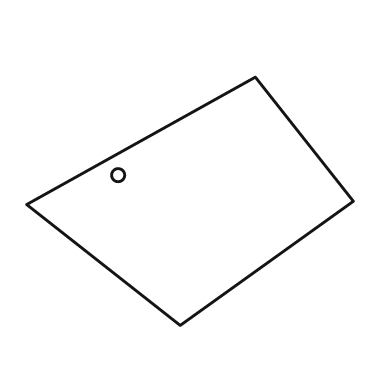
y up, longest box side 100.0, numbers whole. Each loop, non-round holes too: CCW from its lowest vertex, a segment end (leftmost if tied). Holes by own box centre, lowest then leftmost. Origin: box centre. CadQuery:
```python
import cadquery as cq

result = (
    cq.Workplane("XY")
    .moveTo(-3.0, -38.0)
    .lineTo(50.0, 0.0)
    .lineTo(20.0, 38.0)
    .lineTo(-50.0, -1.0)
    .close()
    .moveTo(-22.0, 8.0)
    .circle(2.0)
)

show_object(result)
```